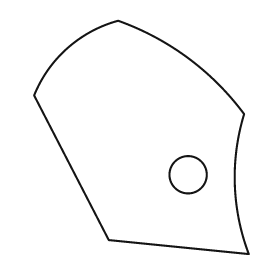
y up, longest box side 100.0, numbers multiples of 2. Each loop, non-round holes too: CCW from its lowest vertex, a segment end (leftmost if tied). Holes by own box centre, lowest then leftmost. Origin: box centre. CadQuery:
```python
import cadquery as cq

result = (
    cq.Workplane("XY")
    .moveTo(46.0, -50.0)
    .threePointArc((40.0, -20.0), (44.0, 10.0))
    .threePointArc((20.0, 34.0), (-10.0, 50.0))
    .threePointArc((-32.0, 38.0), (-46.0, 18.0))
    .lineTo(-14.0, -44.0)
    .close()
    .moveTo(20.0, -16.0)
    .circle(8.0)
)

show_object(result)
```